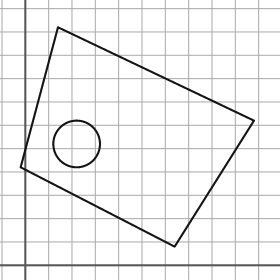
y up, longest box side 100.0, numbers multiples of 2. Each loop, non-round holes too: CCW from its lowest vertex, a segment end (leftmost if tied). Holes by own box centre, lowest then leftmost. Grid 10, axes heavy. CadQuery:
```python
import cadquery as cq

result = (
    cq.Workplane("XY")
    .moveTo(64.0, 8.0)
    .lineTo(98.0, 62.0)
    .lineTo(14.0, 102.0)
    .lineTo(-2.0, 42.0)
    .close()
    .moveTo(22.0, 52.0)
    .circle(10.0)
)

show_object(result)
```